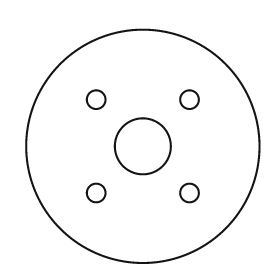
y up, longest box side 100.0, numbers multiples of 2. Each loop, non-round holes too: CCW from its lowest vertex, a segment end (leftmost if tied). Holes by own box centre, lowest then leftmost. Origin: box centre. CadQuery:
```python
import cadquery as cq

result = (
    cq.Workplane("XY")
    .moveTo(0.0, 0.0)
    .circle(50.0)
    .moveTo(-20.0, -20.0)
    .circle(4.0)
    .moveTo(20.0, -20.0)
    .circle(4.0)
    .moveTo(0.0, 0.0)
    .circle(12.0)
    .moveTo(-20.0, 20.0)
    .circle(4.0)
    .moveTo(20.0, 20.0)
    .circle(4.0)
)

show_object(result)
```